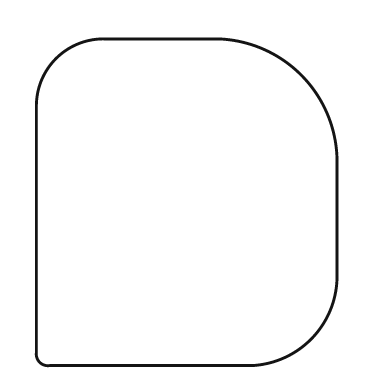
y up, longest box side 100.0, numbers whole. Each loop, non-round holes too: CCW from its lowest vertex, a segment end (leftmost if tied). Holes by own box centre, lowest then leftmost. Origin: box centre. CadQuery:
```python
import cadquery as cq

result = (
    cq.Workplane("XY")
    .moveTo(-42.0, -50.0)
    .lineTo(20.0, -50.0)
    .threePointArc((38.0, -42.0), (46.0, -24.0))
    .lineTo(46.0, 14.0)
    .threePointArc((35.0, 39.0), (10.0, 50.0))
    .lineTo(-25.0, 50.0)
    .threePointArc((-40.0, 44.0), (-46.0, 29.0))
    .lineTo(-46.0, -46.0)
    .threePointArc((-45.0, -49.0), (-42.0, -50.0))
    .close()
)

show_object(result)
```